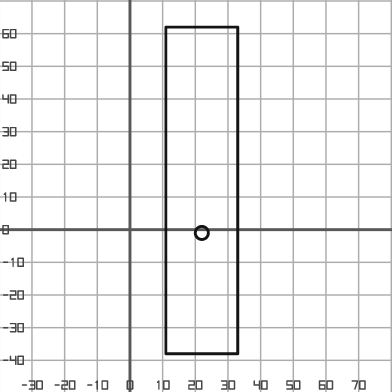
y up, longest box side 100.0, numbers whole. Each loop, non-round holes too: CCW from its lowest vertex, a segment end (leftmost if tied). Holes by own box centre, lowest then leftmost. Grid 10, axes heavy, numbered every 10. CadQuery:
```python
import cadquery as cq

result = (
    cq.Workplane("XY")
    .moveTo(11.0, -38.0)
    .lineTo(33.0, -38.0)
    .lineTo(33.0, 62.0)
    .lineTo(11.0, 62.0)
    .close()
    .moveTo(22.0, -1.0)
    .circle(2.0)
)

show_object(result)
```